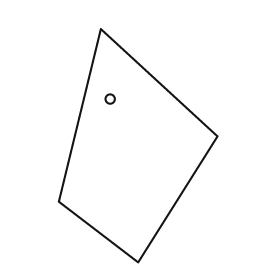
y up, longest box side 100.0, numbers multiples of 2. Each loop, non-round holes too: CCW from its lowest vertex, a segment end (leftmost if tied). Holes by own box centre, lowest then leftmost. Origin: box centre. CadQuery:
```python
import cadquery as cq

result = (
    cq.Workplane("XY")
    .moveTo(0.0, -50.0)
    .lineTo(34.0, 4.0)
    .lineTo(-16.0, 50.0)
    .lineTo(-34.0, -24.0)
    .close()
    .moveTo(-12.0, 20.0)
    .circle(2.0)
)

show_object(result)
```